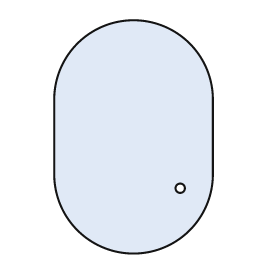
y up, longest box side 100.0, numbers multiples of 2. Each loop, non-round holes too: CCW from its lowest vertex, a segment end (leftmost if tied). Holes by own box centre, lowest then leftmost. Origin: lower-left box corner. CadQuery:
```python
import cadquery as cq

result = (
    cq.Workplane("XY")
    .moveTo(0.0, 34.0)
    .threePointArc((34.0, 0.0), (68.0, 34.0))
    .lineTo(68.0, 66.0)
    .threePointArc((34.0, 100.0), (0.0, 66.0))
    .close()
    .moveTo(54.0, 28.0)
    .circle(2.0)
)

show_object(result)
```